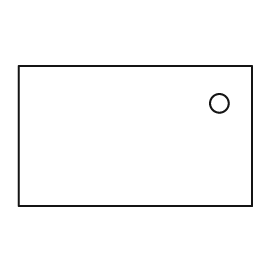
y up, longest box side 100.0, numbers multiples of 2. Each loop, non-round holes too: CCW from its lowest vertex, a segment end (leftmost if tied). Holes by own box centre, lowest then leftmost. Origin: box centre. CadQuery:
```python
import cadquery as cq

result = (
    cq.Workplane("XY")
    .moveTo(-50.0, -30.0)
    .lineTo(50.0, -30.0)
    .lineTo(50.0, 30.0)
    .lineTo(-50.0, 30.0)
    .close()
    .moveTo(36.0, 14.0)
    .circle(4.0)
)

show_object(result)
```